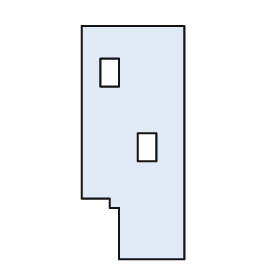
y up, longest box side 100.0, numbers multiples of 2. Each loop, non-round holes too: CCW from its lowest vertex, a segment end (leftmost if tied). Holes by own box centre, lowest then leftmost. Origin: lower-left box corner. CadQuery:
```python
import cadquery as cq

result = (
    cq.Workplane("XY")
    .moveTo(16.0, 0.0)
    .lineTo(44.0, 0.0)
    .lineTo(44.0, 100.0)
    .lineTo(0.0, 100.0)
    .lineTo(0.0, 26.0)
    .lineTo(12.0, 26.0)
    .lineTo(12.0, 22.0)
    .lineTo(16.0, 22.0)
    .close()
    .moveTo(24.0, 42.0)
    .lineTo(32.0, 42.0)
    .lineTo(32.0, 54.0)
    .lineTo(24.0, 54.0)
    .close()
    .moveTo(8.0, 74.0)
    .lineTo(16.0, 74.0)
    .lineTo(16.0, 86.0)
    .lineTo(8.0, 86.0)
    .close()
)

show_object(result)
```